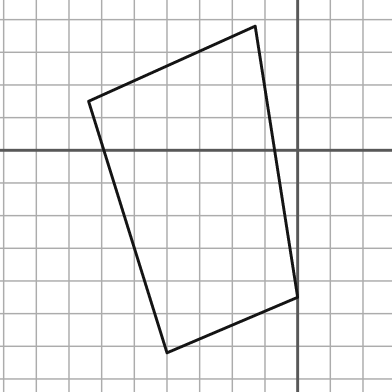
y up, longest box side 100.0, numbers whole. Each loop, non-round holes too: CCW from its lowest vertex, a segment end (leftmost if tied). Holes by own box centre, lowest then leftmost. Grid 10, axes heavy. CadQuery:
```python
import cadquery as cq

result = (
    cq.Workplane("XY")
    .moveTo(-40.0, -62.0)
    .lineTo(0.0, -45.0)
    .lineTo(-13.0, 38.0)
    .lineTo(-64.0, 15.0)
    .close()
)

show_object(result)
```